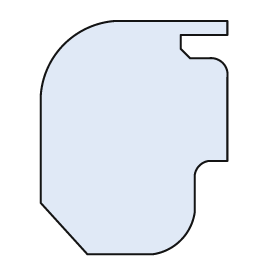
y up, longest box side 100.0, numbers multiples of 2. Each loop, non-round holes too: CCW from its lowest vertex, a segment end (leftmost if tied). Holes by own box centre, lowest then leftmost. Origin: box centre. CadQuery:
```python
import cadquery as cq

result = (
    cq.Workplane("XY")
    .moveTo(-20.0, -50.0)
    .lineTo(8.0, -50.0)
    .threePointArc((20.0, -44.0), (26.0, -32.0))
    .lineTo(26.0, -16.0)
    .threePointArc((28.0, -12.0), (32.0, -10.0))
    .lineTo(40.0, -10.0)
    .lineTo(40.0, 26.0)
    .threePointArc((38.0, 32.0), (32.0, 34.0))
    .lineTo(24.0, 34.0)
    .lineTo(20.0, 38.0)
    .lineTo(20.0, 44.0)
    .lineTo(40.0, 44.0)
    .lineTo(40.0, 50.0)
    .lineTo(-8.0, 50.0)
    .threePointArc((-30.0, 40.0), (-40.0, 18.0))
    .lineTo(-40.0, -28.0)
    .close()
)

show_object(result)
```